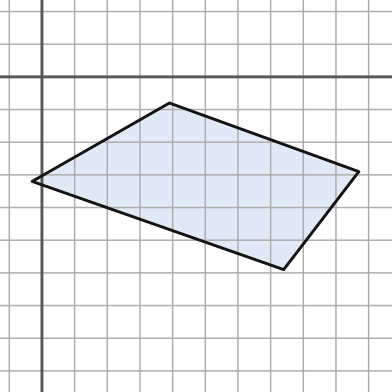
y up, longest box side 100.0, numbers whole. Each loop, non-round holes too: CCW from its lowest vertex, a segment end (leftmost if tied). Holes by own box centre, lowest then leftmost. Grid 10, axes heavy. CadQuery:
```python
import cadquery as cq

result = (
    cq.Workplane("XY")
    .moveTo(74.0, -59.0)
    .lineTo(97.0, -29.0)
    .lineTo(39.0, -8.0)
    .lineTo(-3.0, -32.0)
    .close()
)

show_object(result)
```